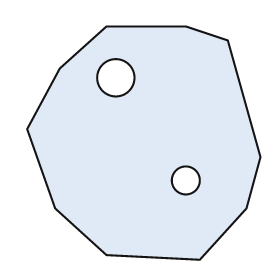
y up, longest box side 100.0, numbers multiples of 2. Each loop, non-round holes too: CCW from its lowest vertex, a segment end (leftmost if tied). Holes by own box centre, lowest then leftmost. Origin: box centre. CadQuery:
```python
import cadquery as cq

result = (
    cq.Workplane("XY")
    .moveTo(24.0, -50.0)
    .lineTo(44.0, -28.0)
    .lineTo(50.0, -6.0)
    .lineTo(36.0, 44.0)
    .lineTo(18.0, 50.0)
    .lineTo(-16.0, 50.0)
    .lineTo(-36.0, 32.0)
    .lineTo(-50.0, 6.0)
    .lineTo(-38.0, -28.0)
    .lineTo(-16.0, -48.0)
    .close()
    .moveTo(18.0, -16.0)
    .circle(6.0)
    .moveTo(-12.0, 28.0)
    .circle(8.0)
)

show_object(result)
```